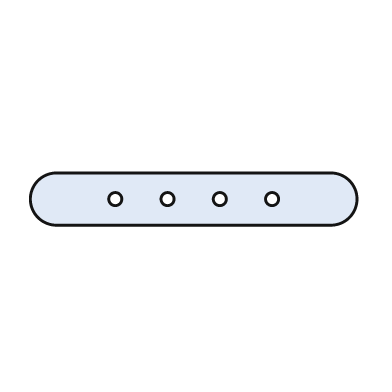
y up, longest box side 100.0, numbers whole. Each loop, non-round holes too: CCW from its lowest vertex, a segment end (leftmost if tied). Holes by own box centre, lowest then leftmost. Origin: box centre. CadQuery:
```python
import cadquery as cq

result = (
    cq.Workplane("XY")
    .moveTo(-42.0, -8.0)
    .lineTo(42.0, -8.0)
    .threePointArc((50.0, 0.0), (42.0, 8.0))
    .lineTo(-42.0, 8.0)
    .threePointArc((-50.0, 0.0), (-42.0, -8.0))
    .close()
    .moveTo(-24.0, 0.0)
    .circle(2.0)
    .moveTo(-8.0, 0.0)
    .circle(2.0)
    .moveTo(8.0, 0.0)
    .circle(2.0)
    .moveTo(24.0, 0.0)
    .circle(2.0)
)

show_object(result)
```